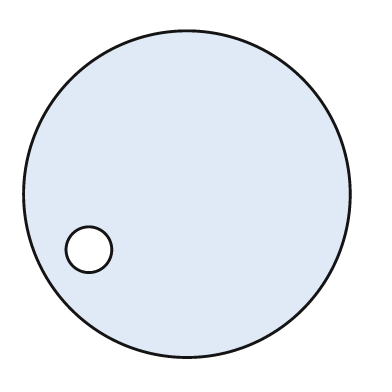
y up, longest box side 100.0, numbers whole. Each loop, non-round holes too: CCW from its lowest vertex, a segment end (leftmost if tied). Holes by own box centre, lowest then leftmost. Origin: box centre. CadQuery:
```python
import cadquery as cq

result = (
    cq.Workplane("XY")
    .moveTo(0.0, 0.0)
    .circle(50.0)
    .moveTo(-30.0, -17.0)
    .circle(7.0)
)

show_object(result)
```